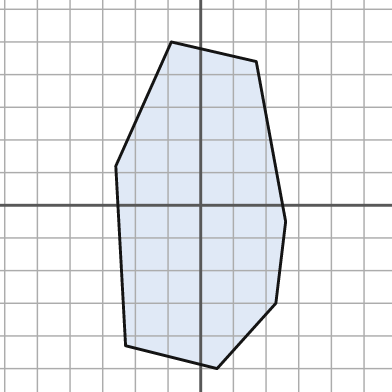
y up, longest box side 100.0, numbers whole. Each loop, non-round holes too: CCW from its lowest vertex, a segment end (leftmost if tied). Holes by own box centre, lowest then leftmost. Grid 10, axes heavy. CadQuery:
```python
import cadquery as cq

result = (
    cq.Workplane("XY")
    .moveTo(5.0, -50.0)
    .lineTo(23.0, -30.0)
    .lineTo(26.0, -5.0)
    .lineTo(17.0, 44.0)
    .lineTo(-9.0, 50.0)
    .lineTo(-26.0, 12.0)
    .lineTo(-23.0, -43.0)
    .close()
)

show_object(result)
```